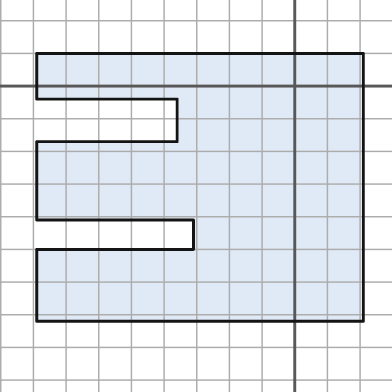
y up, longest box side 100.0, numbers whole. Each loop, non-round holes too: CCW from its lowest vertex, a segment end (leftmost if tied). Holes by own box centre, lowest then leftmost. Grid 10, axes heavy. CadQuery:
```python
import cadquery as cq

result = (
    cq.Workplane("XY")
    .moveTo(-79.0, -72.0)
    .lineTo(21.0, -72.0)
    .lineTo(21.0, 10.0)
    .lineTo(-79.0, 10.0)
    .lineTo(-79.0, -4.0)
    .lineTo(-36.0, -4.0)
    .lineTo(-36.0, -17.0)
    .lineTo(-79.0, -17.0)
    .lineTo(-79.0, -41.0)
    .lineTo(-31.0, -41.0)
    .lineTo(-31.0, -50.0)
    .lineTo(-79.0, -50.0)
    .close()
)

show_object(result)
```